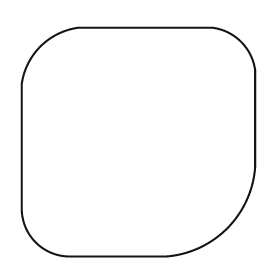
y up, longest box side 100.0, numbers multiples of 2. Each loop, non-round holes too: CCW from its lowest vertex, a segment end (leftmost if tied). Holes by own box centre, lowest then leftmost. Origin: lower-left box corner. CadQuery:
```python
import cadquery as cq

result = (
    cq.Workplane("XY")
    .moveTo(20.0, 0.0)
    .lineTo(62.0, 0.0)
    .threePointArc((88.0, 12.0), (100.0, 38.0))
    .lineTo(100.0, 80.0)
    .threePointArc((94.0, 92.0), (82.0, 98.0))
    .lineTo(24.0, 98.0)
    .threePointArc((8.0, 90.0), (0.0, 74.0))
    .lineTo(0.0, 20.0)
    .threePointArc((6.0, 6.0), (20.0, 0.0))
    .close()
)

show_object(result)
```